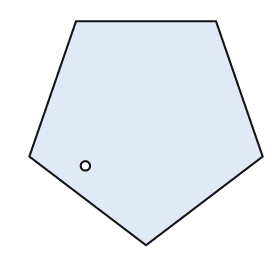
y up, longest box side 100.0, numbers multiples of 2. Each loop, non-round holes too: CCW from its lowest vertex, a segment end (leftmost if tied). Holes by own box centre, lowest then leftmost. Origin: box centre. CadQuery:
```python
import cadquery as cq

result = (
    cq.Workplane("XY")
    .moveTo(0.0, -48.0)
    .lineTo(50.0, -10.0)
    .lineTo(30.0, 48.0)
    .lineTo(-30.0, 48.0)
    .lineTo(-50.0, -10.0)
    .close()
    .moveTo(-26.0, -14.0)
    .circle(2.0)
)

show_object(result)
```